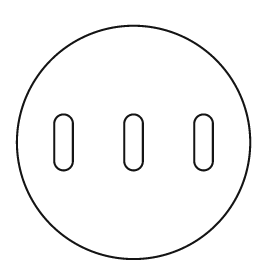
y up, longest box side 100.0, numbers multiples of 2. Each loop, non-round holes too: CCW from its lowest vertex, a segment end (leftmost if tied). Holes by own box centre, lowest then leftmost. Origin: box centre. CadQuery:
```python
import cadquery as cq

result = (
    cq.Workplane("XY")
    .moveTo(0.0, 0.0)
    .circle(50.0)
    .moveTo(-34.0, -8.0)
    .threePointArc((-30.0, -12.0), (-26.0, -8.0))
    .lineTo(-26.0, 8.0)
    .threePointArc((-30.0, 12.0), (-34.0, 8.0))
    .close()
    .moveTo(-4.0, -8.0)
    .threePointArc((0.0, -12.0), (4.0, -8.0))
    .lineTo(4.0, 8.0)
    .threePointArc((0.0, 12.0), (-4.0, 8.0))
    .close()
    .moveTo(26.0, -8.0)
    .threePointArc((30.0, -12.0), (34.0, -8.0))
    .lineTo(34.0, 8.0)
    .threePointArc((30.0, 12.0), (26.0, 8.0))
    .close()
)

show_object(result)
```